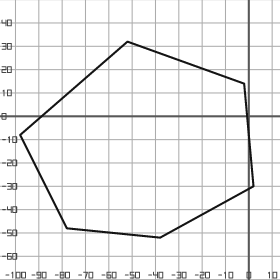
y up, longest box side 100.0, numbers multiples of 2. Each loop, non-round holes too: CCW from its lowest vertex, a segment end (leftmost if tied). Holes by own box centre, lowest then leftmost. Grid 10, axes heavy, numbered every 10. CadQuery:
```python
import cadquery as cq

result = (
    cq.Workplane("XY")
    .moveTo(-38.0, -52.0)
    .lineTo(2.0, -30.0)
    .lineTo(-2.0, 14.0)
    .lineTo(-52.0, 32.0)
    .lineTo(-98.0, -8.0)
    .lineTo(-78.0, -48.0)
    .close()
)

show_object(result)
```